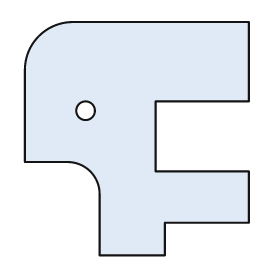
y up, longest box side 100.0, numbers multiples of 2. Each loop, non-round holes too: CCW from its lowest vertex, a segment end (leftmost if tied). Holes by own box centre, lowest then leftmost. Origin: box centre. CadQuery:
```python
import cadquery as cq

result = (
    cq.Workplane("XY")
    .moveTo(-16.0, -50.0)
    .lineTo(12.0, -50.0)
    .lineTo(12.0, -36.0)
    .lineTo(48.0, -36.0)
    .lineTo(48.0, -14.0)
    .lineTo(8.0, -14.0)
    .lineTo(8.0, 16.0)
    .lineTo(48.0, 16.0)
    .lineTo(48.0, 50.0)
    .lineTo(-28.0, 50.0)
    .threePointArc((-42.0, 44.0), (-48.0, 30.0))
    .lineTo(-48.0, -10.0)
    .lineTo(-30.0, -10.0)
    .threePointArc((-20.0, -14.0), (-16.0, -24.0))
    .close()
    .moveTo(-22.0, 12.0)
    .circle(4.0)
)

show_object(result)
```